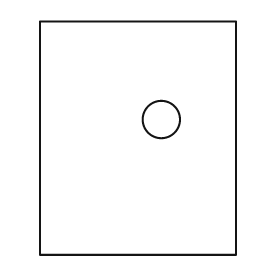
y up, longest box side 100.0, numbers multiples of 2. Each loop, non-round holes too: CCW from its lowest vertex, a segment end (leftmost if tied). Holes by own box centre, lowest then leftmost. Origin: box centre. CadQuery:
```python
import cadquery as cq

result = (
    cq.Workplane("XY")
    .moveTo(-42.0, -50.0)
    .lineTo(42.0, -50.0)
    .lineTo(42.0, 50.0)
    .lineTo(-42.0, 50.0)
    .close()
    .moveTo(10.0, 8.0)
    .circle(8.0)
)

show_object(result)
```